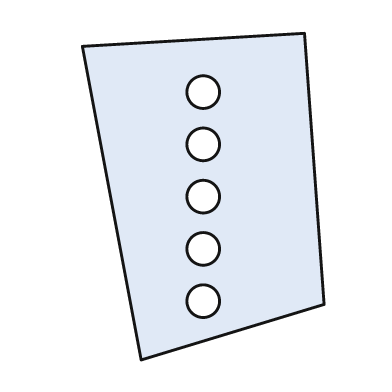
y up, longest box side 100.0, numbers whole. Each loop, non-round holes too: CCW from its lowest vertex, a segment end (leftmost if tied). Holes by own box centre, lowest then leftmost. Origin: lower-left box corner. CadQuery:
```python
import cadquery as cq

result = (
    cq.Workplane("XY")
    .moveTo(18.0, 0.0)
    .lineTo(74.0, 17.0)
    .lineTo(68.0, 100.0)
    .lineTo(0.0, 96.0)
    .close()
    .moveTo(37.0, 18.0)
    .circle(5.0)
    .moveTo(37.0, 34.0)
    .circle(5.0)
    .moveTo(37.0, 50.0)
    .circle(5.0)
    .moveTo(37.0, 66.0)
    .circle(5.0)
    .moveTo(37.0, 82.0)
    .circle(5.0)
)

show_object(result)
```